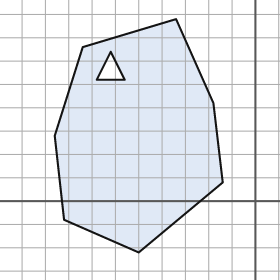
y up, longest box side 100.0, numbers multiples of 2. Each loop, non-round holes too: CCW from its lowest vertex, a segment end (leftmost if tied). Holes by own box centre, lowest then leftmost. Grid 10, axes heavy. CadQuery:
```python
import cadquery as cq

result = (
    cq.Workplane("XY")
    .moveTo(-50.0, -22.0)
    .lineTo(-14.0, 8.0)
    .lineTo(-18.0, 42.0)
    .lineTo(-34.0, 78.0)
    .lineTo(-74.0, 66.0)
    .lineTo(-86.0, 28.0)
    .lineTo(-82.0, -8.0)
    .close()
    .moveTo(-68.0, 52.0)
    .lineTo(-56.0, 52.0)
    .lineTo(-62.0, 64.0)
    .close()
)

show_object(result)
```